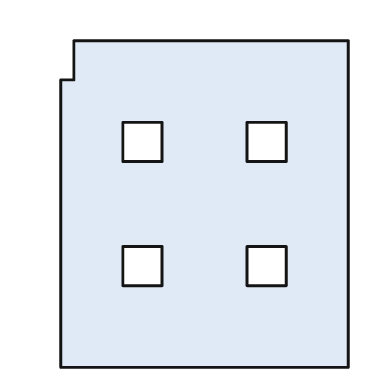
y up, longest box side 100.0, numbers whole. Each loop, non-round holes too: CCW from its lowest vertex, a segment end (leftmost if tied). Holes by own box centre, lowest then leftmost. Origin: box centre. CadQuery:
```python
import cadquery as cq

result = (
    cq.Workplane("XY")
    .moveTo(-44.0, -50.0)
    .lineTo(44.0, -50.0)
    .lineTo(44.0, 50.0)
    .lineTo(-40.0, 50.0)
    .lineTo(-40.0, 38.0)
    .lineTo(-44.0, 38.0)
    .close()
    .moveTo(-25.0, -25.0)
    .lineTo(-13.0, -25.0)
    .lineTo(-13.0, -13.0)
    .lineTo(-25.0, -13.0)
    .close()
    .moveTo(13.0, -25.0)
    .lineTo(25.0, -25.0)
    .lineTo(25.0, -13.0)
    .lineTo(13.0, -13.0)
    .close()
    .moveTo(-25.0, 13.0)
    .lineTo(-13.0, 13.0)
    .lineTo(-13.0, 25.0)
    .lineTo(-25.0, 25.0)
    .close()
    .moveTo(13.0, 13.0)
    .lineTo(25.0, 13.0)
    .lineTo(25.0, 25.0)
    .lineTo(13.0, 25.0)
    .close()
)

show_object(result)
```